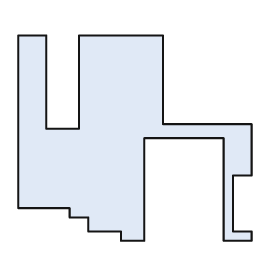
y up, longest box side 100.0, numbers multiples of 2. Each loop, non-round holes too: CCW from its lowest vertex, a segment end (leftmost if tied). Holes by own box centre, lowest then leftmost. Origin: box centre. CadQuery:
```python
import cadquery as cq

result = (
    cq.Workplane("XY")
    .moveTo(-6.0, -44.0)
    .lineTo(4.0, -44.0)
    .lineTo(4.0, 0.0)
    .lineTo(38.0, 0.0)
    .lineTo(38.0, -44.0)
    .lineTo(50.0, -44.0)
    .lineTo(50.0, -40.0)
    .lineTo(42.0, -40.0)
    .lineTo(42.0, -16.0)
    .lineTo(50.0, -16.0)
    .lineTo(50.0, 6.0)
    .lineTo(12.0, 6.0)
    .lineTo(12.0, 44.0)
    .lineTo(-24.0, 44.0)
    .lineTo(-24.0, 4.0)
    .lineTo(-38.0, 4.0)
    .lineTo(-38.0, 44.0)
    .lineTo(-50.0, 44.0)
    .lineTo(-50.0, -30.0)
    .lineTo(-28.0, -30.0)
    .lineTo(-28.0, -34.0)
    .lineTo(-20.0, -34.0)
    .lineTo(-20.0, -40.0)
    .lineTo(-6.0, -40.0)
    .close()
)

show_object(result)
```